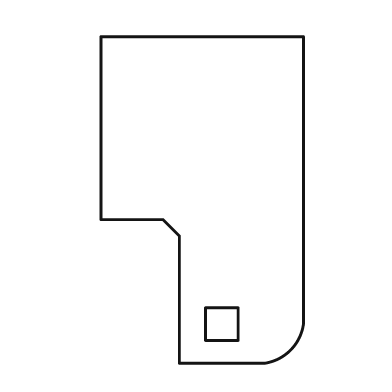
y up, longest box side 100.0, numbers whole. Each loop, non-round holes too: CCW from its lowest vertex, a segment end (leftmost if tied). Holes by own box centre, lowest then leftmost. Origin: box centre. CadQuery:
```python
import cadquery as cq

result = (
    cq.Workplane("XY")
    .moveTo(-7.0, -50.0)
    .lineTo(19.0, -50.0)
    .threePointArc((27.0, -46.0), (31.0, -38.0))
    .lineTo(31.0, 50.0)
    .lineTo(-31.0, 50.0)
    .lineTo(-31.0, -6.0)
    .lineTo(-12.0, -6.0)
    .lineTo(-7.0, -11.0)
    .close()
    .moveTo(1.0, -43.0)
    .lineTo(11.0, -43.0)
    .lineTo(11.0, -33.0)
    .lineTo(1.0, -33.0)
    .close()
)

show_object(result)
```